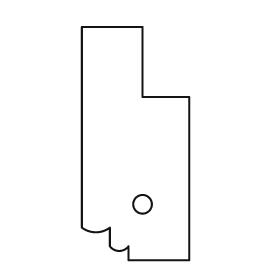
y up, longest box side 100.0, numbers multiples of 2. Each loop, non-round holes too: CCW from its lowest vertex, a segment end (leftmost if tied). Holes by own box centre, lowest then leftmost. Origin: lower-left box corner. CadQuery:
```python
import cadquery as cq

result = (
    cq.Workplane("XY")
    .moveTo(20.0, 0.0)
    .lineTo(46.0, 0.0)
    .lineTo(46.0, 70.0)
    .lineTo(26.0, 70.0)
    .lineTo(26.0, 100.0)
    .lineTo(0.0, 100.0)
    .lineTo(0.0, 14.0)
    .threePointArc((6.0, 12.0), (12.0, 14.0))
    .lineTo(12.0, 6.0)
    .threePointArc((16.0, 4.0), (20.0, 6.0))
    .close()
    .moveTo(26.0, 24.0)
    .circle(4.0)
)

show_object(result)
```